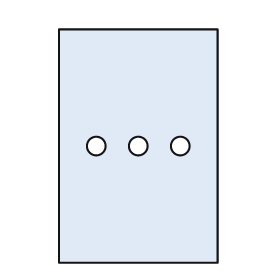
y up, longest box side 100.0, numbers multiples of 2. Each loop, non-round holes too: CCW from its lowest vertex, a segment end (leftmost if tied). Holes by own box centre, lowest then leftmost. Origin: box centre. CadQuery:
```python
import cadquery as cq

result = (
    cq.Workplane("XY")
    .moveTo(-34.0, -50.0)
    .lineTo(34.0, -50.0)
    .lineTo(34.0, 50.0)
    .lineTo(-34.0, 50.0)
    .close()
    .moveTo(-18.0, 0.0)
    .circle(4.0)
    .moveTo(0.0, 0.0)
    .circle(4.0)
    .moveTo(18.0, 0.0)
    .circle(4.0)
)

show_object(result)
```